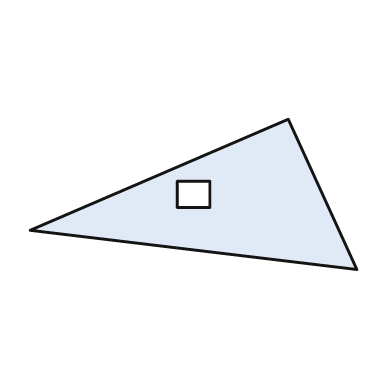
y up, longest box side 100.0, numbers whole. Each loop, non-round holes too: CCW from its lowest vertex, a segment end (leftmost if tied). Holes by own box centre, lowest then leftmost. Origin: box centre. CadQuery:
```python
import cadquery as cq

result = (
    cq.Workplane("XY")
    .moveTo(50.0, -23.0)
    .lineTo(29.0, 23.0)
    .lineTo(-50.0, -11.0)
    .close()
    .moveTo(-5.0, -4.0)
    .lineTo(5.0, -4.0)
    .lineTo(5.0, 4.0)
    .lineTo(-5.0, 4.0)
    .close()
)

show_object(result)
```